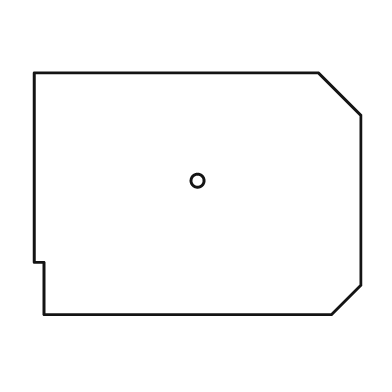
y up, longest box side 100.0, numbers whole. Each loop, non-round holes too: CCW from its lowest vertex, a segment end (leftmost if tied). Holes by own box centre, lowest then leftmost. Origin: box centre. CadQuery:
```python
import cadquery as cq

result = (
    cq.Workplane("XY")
    .moveTo(-47.0, -37.0)
    .lineTo(41.0, -37.0)
    .lineTo(50.0, -28.0)
    .lineTo(50.0, 24.0)
    .lineTo(37.0, 37.0)
    .lineTo(-50.0, 37.0)
    .lineTo(-50.0, -21.0)
    .lineTo(-47.0, -21.0)
    .close()
    .moveTo(0.0, 4.0)
    .circle(2.0)
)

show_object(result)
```